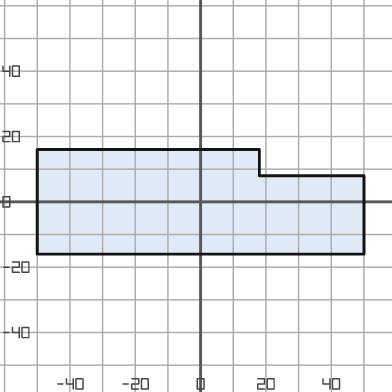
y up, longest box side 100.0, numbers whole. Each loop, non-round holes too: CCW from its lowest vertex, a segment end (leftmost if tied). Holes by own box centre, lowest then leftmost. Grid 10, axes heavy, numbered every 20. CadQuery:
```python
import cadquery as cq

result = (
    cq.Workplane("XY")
    .moveTo(-50.0, -16.0)
    .lineTo(50.0, -16.0)
    .lineTo(50.0, 8.0)
    .lineTo(18.0, 8.0)
    .lineTo(18.0, 16.0)
    .lineTo(-50.0, 16.0)
    .close()
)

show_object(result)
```